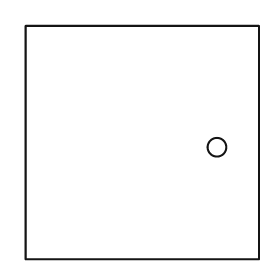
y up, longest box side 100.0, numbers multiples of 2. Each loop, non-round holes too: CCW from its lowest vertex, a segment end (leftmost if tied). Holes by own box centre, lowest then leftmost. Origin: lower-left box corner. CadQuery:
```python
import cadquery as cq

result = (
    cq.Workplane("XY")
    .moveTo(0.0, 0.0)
    .lineTo(100.0, 0.0)
    .lineTo(100.0, 100.0)
    .lineTo(0.0, 100.0)
    .close()
    .moveTo(82.0, 48.0)
    .circle(4.0)
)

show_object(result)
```